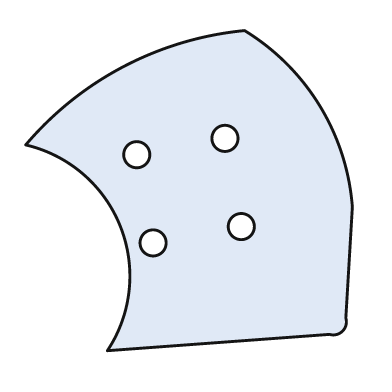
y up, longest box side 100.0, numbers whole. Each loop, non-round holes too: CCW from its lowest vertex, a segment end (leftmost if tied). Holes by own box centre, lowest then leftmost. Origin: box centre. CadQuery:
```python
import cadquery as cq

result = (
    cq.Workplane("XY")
    .moveTo(-25.0, -49.0)
    .lineTo(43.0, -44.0)
    .threePointArc((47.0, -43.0), (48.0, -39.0))
    .lineTo(50.0, -5.0)
    .threePointArc((40.0, 26.0), (17.0, 49.0))
    .threePointArc((-20.0, 38.0), (-50.0, 14.0))
    .threePointArc((-21.0, -11.0), (-25.0, -49.0))
    .close()
    .moveTo(-11.0, -16.0)
    .circle(4.0)
    .moveTo(16.0, -11.0)
    .circle(4.0)
    .moveTo(-16.0, 11.0)
    .circle(4.0)
    .moveTo(11.0, 16.0)
    .circle(4.0)
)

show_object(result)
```